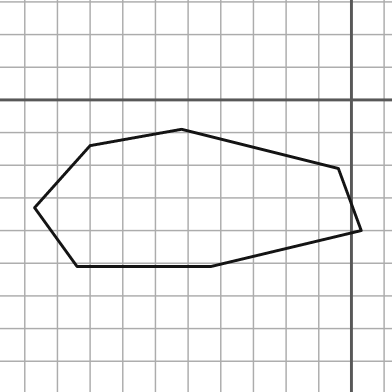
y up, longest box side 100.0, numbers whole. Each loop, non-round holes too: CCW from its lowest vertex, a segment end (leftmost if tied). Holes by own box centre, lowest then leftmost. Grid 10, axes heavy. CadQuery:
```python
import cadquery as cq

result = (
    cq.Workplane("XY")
    .moveTo(-84.0, -51.0)
    .lineTo(-43.0, -51.0)
    .lineTo(3.0, -40.0)
    .lineTo(-4.0, -21.0)
    .lineTo(-52.0, -9.0)
    .lineTo(-80.0, -14.0)
    .lineTo(-97.0, -33.0)
    .close()
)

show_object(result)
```